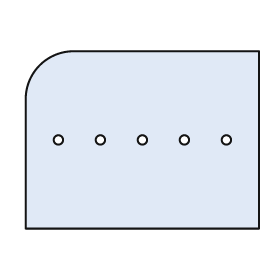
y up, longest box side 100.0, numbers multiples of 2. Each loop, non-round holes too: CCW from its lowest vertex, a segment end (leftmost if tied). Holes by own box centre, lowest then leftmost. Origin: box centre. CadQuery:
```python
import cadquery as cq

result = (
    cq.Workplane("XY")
    .moveTo(-50.0, -38.0)
    .lineTo(50.0, -38.0)
    .lineTo(50.0, 38.0)
    .lineTo(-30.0, 38.0)
    .threePointArc((-44.0, 32.0), (-50.0, 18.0))
    .close()
    .moveTo(-36.0, 0.0)
    .circle(2.0)
    .moveTo(-18.0, 0.0)
    .circle(2.0)
    .moveTo(0.0, 0.0)
    .circle(2.0)
    .moveTo(18.0, 0.0)
    .circle(2.0)
    .moveTo(36.0, 0.0)
    .circle(2.0)
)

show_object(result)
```